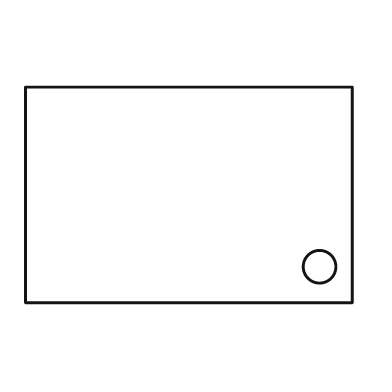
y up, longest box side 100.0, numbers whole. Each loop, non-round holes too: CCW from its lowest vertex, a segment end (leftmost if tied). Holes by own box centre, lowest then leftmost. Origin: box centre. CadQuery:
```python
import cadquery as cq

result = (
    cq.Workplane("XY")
    .moveTo(-50.0, -33.0)
    .lineTo(50.0, -33.0)
    .lineTo(50.0, 33.0)
    .lineTo(-50.0, 33.0)
    .close()
    .moveTo(40.0, -22.0)
    .circle(5.0)
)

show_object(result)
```